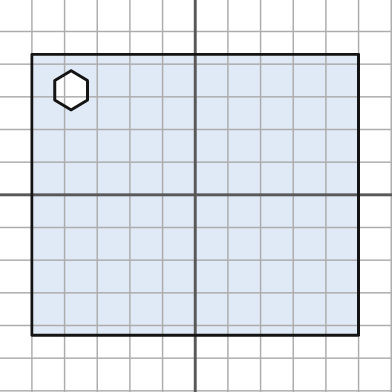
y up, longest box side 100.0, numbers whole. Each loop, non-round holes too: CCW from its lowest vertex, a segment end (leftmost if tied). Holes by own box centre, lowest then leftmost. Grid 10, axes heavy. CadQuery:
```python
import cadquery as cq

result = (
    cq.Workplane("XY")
    .moveTo(-50.0, -43.0)
    .lineTo(50.0, -43.0)
    .lineTo(50.0, 43.0)
    .lineTo(-50.0, 43.0)
    .close()
    .moveTo(-38.0, 26.0)
    .lineTo(-33.0, 29.0)
    .lineTo(-33.0, 35.0)
    .lineTo(-38.0, 38.0)
    .lineTo(-43.0, 35.0)
    .lineTo(-43.0, 29.0)
    .close()
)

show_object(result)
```